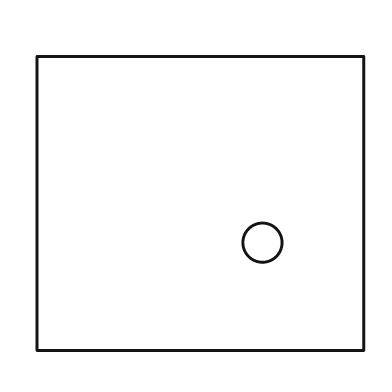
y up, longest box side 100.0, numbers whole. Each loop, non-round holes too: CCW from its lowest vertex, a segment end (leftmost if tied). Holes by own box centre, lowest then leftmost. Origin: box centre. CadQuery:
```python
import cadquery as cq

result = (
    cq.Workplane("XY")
    .moveTo(-50.0, -45.0)
    .lineTo(50.0, -45.0)
    .lineTo(50.0, 45.0)
    .lineTo(-50.0, 45.0)
    .close()
    .moveTo(19.0, -12.0)
    .circle(6.0)
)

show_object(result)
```